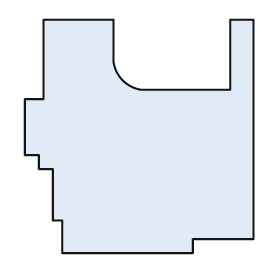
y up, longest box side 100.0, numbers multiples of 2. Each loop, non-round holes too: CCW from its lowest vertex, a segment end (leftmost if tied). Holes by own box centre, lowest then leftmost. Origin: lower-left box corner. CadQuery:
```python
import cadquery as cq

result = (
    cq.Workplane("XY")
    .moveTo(16.0, 0.0)
    .lineTo(72.0, 0.0)
    .lineTo(72.0, 6.0)
    .lineTo(98.0, 6.0)
    .lineTo(98.0, 100.0)
    .lineTo(88.0, 100.0)
    .lineTo(88.0, 70.0)
    .lineTo(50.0, 70.0)
    .threePointArc((42.0, 74.0), (38.0, 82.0))
    .lineTo(38.0, 100.0)
    .lineTo(8.0, 100.0)
    .lineTo(8.0, 66.0)
    .lineTo(0.0, 66.0)
    .lineTo(0.0, 42.0)
    .lineTo(6.0, 42.0)
    .lineTo(6.0, 36.0)
    .lineTo(12.0, 36.0)
    .lineTo(12.0, 14.0)
    .lineTo(16.0, 14.0)
    .close()
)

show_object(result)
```